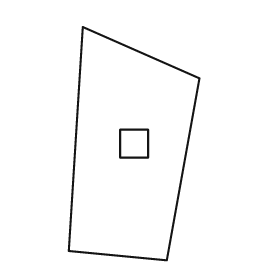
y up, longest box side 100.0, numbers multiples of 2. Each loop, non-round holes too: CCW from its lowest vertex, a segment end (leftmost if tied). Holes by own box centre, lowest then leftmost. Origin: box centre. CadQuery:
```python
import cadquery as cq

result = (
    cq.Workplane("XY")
    .moveTo(14.0, -50.0)
    .lineTo(28.0, 28.0)
    .lineTo(-22.0, 50.0)
    .lineTo(-28.0, -46.0)
    .close()
    .moveTo(-6.0, -6.0)
    .lineTo(6.0, -6.0)
    .lineTo(6.0, 6.0)
    .lineTo(-6.0, 6.0)
    .close()
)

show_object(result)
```